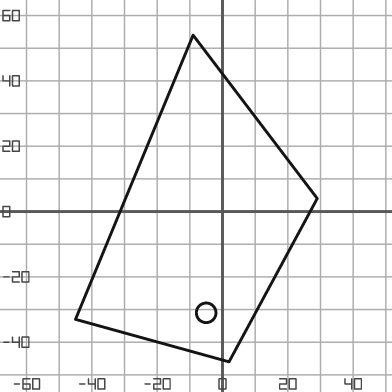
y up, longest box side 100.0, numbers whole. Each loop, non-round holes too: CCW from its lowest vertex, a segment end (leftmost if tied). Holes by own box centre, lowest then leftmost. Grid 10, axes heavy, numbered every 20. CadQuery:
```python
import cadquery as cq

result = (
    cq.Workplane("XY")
    .moveTo(2.0, -46.0)
    .lineTo(29.0, 4.0)
    .lineTo(-9.0, 54.0)
    .lineTo(-45.0, -33.0)
    .close()
    .moveTo(-5.0, -31.0)
    .circle(3.0)
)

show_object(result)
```